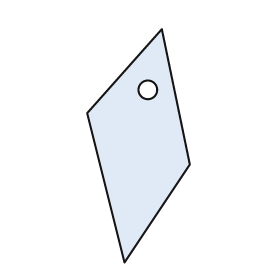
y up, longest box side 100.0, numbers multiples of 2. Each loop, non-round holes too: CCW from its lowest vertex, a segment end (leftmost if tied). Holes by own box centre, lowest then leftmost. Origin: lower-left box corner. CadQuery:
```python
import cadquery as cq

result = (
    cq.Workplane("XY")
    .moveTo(16.0, 0.0)
    .lineTo(44.0, 42.0)
    .lineTo(32.0, 100.0)
    .lineTo(0.0, 64.0)
    .close()
    .moveTo(26.0, 74.0)
    .circle(4.0)
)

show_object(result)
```